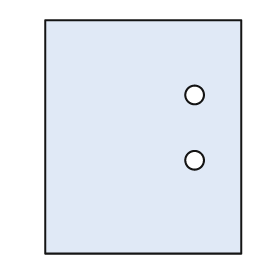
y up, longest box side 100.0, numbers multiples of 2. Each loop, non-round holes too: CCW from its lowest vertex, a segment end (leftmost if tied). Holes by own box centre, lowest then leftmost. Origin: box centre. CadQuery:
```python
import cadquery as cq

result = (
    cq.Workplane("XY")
    .moveTo(-42.0, -50.0)
    .lineTo(42.0, -50.0)
    .lineTo(42.0, 50.0)
    .lineTo(-42.0, 50.0)
    .close()
    .moveTo(22.0, -10.0)
    .circle(4.0)
    .moveTo(22.0, 18.0)
    .circle(4.0)
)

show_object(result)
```